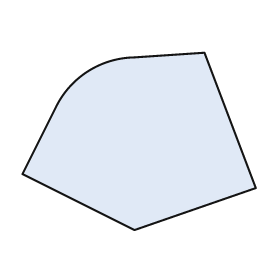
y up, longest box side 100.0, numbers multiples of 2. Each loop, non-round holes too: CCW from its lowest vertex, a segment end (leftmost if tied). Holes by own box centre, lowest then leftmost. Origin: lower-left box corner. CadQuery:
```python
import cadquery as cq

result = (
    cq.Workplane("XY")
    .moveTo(48.0, 0.0)
    .lineTo(100.0, 18.0)
    .lineTo(78.0, 76.0)
    .lineTo(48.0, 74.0)
    .threePointArc((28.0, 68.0), (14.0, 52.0))
    .lineTo(0.0, 24.0)
    .close()
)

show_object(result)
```